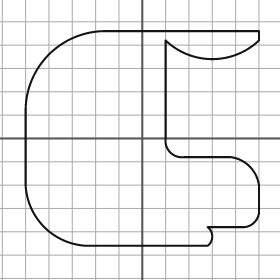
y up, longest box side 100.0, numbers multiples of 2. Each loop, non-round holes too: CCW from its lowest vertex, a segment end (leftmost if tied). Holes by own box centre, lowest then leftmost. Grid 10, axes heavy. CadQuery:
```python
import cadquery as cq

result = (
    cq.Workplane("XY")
    .moveTo(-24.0, -46.0)
    .lineTo(28.0, -46.0)
    .threePointArc((30.0, -42.0), (28.0, -38.0))
    .lineTo(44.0, -38.0)
    .threePointArc((48.0, -36.0), (50.0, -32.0))
    .lineTo(50.0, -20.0)
    .threePointArc((46.0, -12.0), (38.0, -8.0))
    .lineTo(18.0, -8.0)
    .threePointArc((12.0, -6.0), (10.0, 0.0))
    .lineTo(10.0, 42.0)
    .threePointArc((30.0, 34.0), (50.0, 42.0))
    .lineTo(50.0, 46.0)
    .lineTo(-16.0, 46.0)
    .threePointArc((-40.0, 36.0), (-50.0, 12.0))
    .lineTo(-50.0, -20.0)
    .threePointArc((-42.0, -38.0), (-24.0, -46.0))
    .close()
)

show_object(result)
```